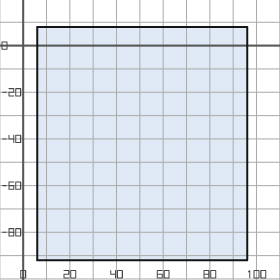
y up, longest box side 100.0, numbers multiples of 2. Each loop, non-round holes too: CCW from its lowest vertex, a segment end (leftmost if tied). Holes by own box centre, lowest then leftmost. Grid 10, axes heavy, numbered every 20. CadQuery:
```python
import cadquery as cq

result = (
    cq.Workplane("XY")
    .moveTo(6.0, -92.0)
    .lineTo(96.0, -92.0)
    .lineTo(96.0, 8.0)
    .lineTo(6.0, 8.0)
    .close()
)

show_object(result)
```